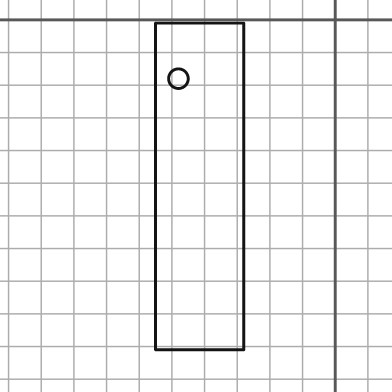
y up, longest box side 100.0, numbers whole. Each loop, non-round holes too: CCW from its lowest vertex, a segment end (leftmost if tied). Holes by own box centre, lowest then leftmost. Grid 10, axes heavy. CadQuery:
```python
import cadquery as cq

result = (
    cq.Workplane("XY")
    .moveTo(-55.0, -101.0)
    .lineTo(-28.0, -101.0)
    .lineTo(-28.0, -1.0)
    .lineTo(-55.0, -1.0)
    .close()
    .moveTo(-48.0, -18.0)
    .circle(3.0)
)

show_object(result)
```